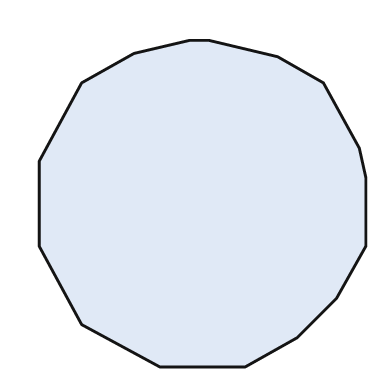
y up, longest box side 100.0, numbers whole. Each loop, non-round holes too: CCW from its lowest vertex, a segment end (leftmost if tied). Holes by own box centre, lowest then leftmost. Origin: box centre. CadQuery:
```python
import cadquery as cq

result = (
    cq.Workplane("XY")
    .moveTo(-13.0, -50.0)
    .lineTo(13.0, -50.0)
    .lineTo(29.0, -41.0)
    .lineTo(41.0, -29.0)
    .lineTo(50.0, -13.0)
    .lineTo(50.0, 8.0)
    .lineTo(48.0, 17.0)
    .lineTo(37.0, 37.0)
    .lineTo(23.0, 45.0)
    .lineTo(2.0, 50.0)
    .lineTo(-4.0, 50.0)
    .lineTo(-21.0, 46.0)
    .lineTo(-37.0, 37.0)
    .lineTo(-50.0, 13.0)
    .lineTo(-50.0, -13.0)
    .lineTo(-37.0, -37.0)
    .close()
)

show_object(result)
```